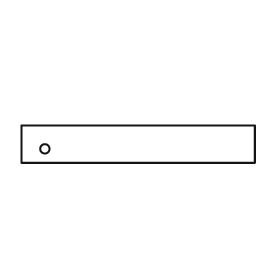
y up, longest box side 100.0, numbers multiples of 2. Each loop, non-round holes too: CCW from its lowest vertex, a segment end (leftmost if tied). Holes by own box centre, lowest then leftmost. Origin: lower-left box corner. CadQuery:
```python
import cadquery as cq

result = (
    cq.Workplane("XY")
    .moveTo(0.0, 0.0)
    .lineTo(100.0, 0.0)
    .lineTo(100.0, 16.0)
    .lineTo(0.0, 16.0)
    .close()
    .moveTo(10.0, 6.0)
    .circle(2.0)
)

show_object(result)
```